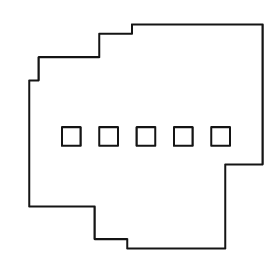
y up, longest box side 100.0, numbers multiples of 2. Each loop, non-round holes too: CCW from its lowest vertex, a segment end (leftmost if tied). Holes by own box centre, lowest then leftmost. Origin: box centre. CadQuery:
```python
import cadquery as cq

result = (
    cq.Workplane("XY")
    .moveTo(-8.0, -48.0)
    .lineTo(34.0, -48.0)
    .lineTo(34.0, -12.0)
    .lineTo(50.0, -12.0)
    .lineTo(50.0, 48.0)
    .lineTo(-6.0, 48.0)
    .lineTo(-6.0, 44.0)
    .lineTo(-20.0, 44.0)
    .lineTo(-20.0, 34.0)
    .lineTo(-46.0, 34.0)
    .lineTo(-46.0, 24.0)
    .lineTo(-50.0, 24.0)
    .lineTo(-50.0, -30.0)
    .lineTo(-22.0, -30.0)
    .lineTo(-22.0, -44.0)
    .lineTo(-8.0, -44.0)
    .close()
    .moveTo(-36.0, -4.0)
    .lineTo(-28.0, -4.0)
    .lineTo(-28.0, 4.0)
    .lineTo(-36.0, 4.0)
    .close()
    .moveTo(-20.0, -4.0)
    .lineTo(-12.0, -4.0)
    .lineTo(-12.0, 4.0)
    .lineTo(-20.0, 4.0)
    .close()
    .moveTo(-4.0, -4.0)
    .lineTo(4.0, -4.0)
    .lineTo(4.0, 4.0)
    .lineTo(-4.0, 4.0)
    .close()
    .moveTo(12.0, -4.0)
    .lineTo(20.0, -4.0)
    .lineTo(20.0, 4.0)
    .lineTo(12.0, 4.0)
    .close()
    .moveTo(28.0, -4.0)
    .lineTo(36.0, -4.0)
    .lineTo(36.0, 4.0)
    .lineTo(28.0, 4.0)
    .close()
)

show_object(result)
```